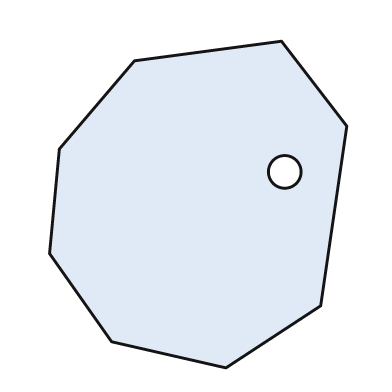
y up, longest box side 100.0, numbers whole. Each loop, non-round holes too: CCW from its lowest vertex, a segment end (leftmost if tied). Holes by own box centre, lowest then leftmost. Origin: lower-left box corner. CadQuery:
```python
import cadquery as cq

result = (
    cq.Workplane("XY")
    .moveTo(54.0, 0.0)
    .lineTo(83.0, 19.0)
    .lineTo(91.0, 74.0)
    .lineTo(71.0, 100.0)
    .lineTo(26.0, 94.0)
    .lineTo(3.0, 67.0)
    .lineTo(0.0, 35.0)
    .lineTo(19.0, 8.0)
    .close()
    .moveTo(72.0, 60.0)
    .circle(5.0)
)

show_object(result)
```